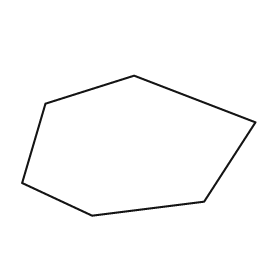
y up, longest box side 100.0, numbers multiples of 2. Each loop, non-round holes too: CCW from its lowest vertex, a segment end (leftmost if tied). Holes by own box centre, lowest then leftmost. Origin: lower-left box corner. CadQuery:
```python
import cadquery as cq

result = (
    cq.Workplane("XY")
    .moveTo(30.0, 0.0)
    .lineTo(78.0, 6.0)
    .lineTo(100.0, 40.0)
    .lineTo(48.0, 60.0)
    .lineTo(10.0, 48.0)
    .lineTo(0.0, 14.0)
    .close()
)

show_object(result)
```